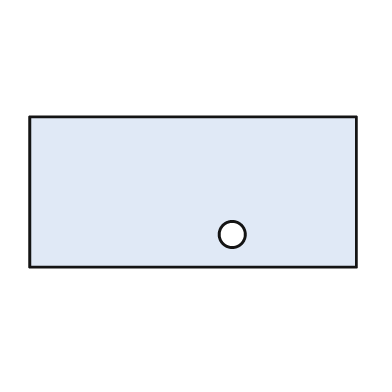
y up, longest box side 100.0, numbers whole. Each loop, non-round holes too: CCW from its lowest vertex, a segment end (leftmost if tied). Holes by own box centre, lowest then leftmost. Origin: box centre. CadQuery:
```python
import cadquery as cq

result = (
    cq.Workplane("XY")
    .moveTo(-50.0, -23.0)
    .lineTo(50.0, -23.0)
    .lineTo(50.0, 23.0)
    .lineTo(-50.0, 23.0)
    .close()
    .moveTo(12.0, -13.0)
    .circle(4.0)
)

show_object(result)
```